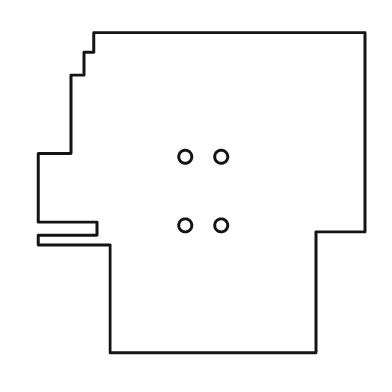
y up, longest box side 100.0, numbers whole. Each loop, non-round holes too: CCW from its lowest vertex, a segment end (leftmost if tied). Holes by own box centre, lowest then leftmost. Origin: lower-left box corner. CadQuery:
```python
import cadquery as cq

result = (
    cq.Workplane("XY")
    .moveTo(22.0, 0.0)
    .lineTo(85.0, 0.0)
    .lineTo(85.0, 37.0)
    .lineTo(100.0, 37.0)
    .lineTo(100.0, 98.0)
    .lineTo(17.0, 98.0)
    .lineTo(17.0, 92.0)
    .lineTo(14.0, 92.0)
    .lineTo(14.0, 85.0)
    .lineTo(10.0, 85.0)
    .lineTo(10.0, 61.0)
    .lineTo(0.0, 61.0)
    .lineTo(0.0, 40.0)
    .lineTo(18.0, 40.0)
    .lineTo(18.0, 36.0)
    .lineTo(0.0, 36.0)
    .lineTo(0.0, 33.0)
    .lineTo(22.0, 33.0)
    .close()
    .moveTo(45.0, 39.0)
    .circle(2.0)
    .moveTo(56.0, 39.0)
    .circle(2.0)
    .moveTo(45.0, 60.0)
    .circle(2.0)
    .moveTo(56.0, 60.0)
    .circle(2.0)
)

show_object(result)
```